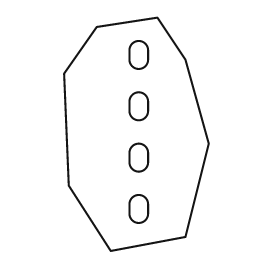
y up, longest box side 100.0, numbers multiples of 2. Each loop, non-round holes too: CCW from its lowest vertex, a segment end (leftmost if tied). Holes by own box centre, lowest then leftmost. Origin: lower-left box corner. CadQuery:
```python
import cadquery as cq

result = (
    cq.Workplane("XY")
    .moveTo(20.0, 0.0)
    .lineTo(52.0, 6.0)
    .lineTo(62.0, 46.0)
    .lineTo(52.0, 82.0)
    .lineTo(40.0, 100.0)
    .lineTo(14.0, 96.0)
    .lineTo(0.0, 76.0)
    .lineTo(2.0, 28.0)
    .close()
    .moveTo(28.0, 16.0)
    .threePointArc((32.0, 12.0), (36.0, 16.0))
    .lineTo(36.0, 20.0)
    .threePointArc((32.0, 24.0), (28.0, 20.0))
    .close()
    .moveTo(28.0, 38.0)
    .threePointArc((32.0, 34.0), (36.0, 38.0))
    .lineTo(36.0, 42.0)
    .threePointArc((32.0, 46.0), (28.0, 42.0))
    .close()
    .moveTo(28.0, 60.0)
    .threePointArc((32.0, 56.0), (36.0, 60.0))
    .lineTo(36.0, 64.0)
    .threePointArc((32.0, 68.0), (28.0, 64.0))
    .close()
    .moveTo(28.0, 82.0)
    .threePointArc((32.0, 78.0), (36.0, 82.0))
    .lineTo(36.0, 86.0)
    .threePointArc((32.0, 90.0), (28.0, 86.0))
    .close()
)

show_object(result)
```